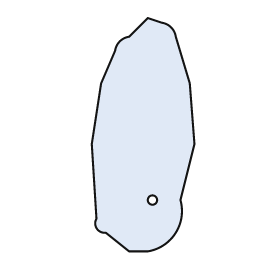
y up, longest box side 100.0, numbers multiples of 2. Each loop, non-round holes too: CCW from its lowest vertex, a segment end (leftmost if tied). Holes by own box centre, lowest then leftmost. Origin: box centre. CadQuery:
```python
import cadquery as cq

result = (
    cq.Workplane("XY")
    .moveTo(-6.0, -50.0)
    .lineTo(2.0, -50.0)
    .threePointArc((14.0, -42.0), (16.0, -28.0))
    .lineTo(22.0, -4.0)
    .lineTo(20.0, 22.0)
    .lineTo(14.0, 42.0)
    .threePointArc((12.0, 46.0), (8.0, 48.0))
    .lineTo(2.0, 50.0)
    .lineTo(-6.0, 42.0)
    .threePointArc((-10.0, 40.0), (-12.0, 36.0))
    .lineTo(-18.0, 22.0)
    .lineTo(-22.0, -4.0)
    .lineTo(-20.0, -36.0)
    .threePointArc((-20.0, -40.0), (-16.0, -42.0))
    .close()
    .moveTo(4.0, -28.0)
    .circle(2.0)
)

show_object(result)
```